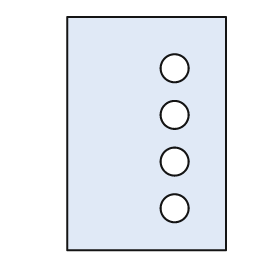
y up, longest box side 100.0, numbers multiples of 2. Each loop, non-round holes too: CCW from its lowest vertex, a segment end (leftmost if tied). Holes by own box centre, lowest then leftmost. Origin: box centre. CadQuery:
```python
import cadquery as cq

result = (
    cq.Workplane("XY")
    .moveTo(-34.0, -50.0)
    .lineTo(34.0, -50.0)
    .lineTo(34.0, 50.0)
    .lineTo(-34.0, 50.0)
    .close()
    .moveTo(12.0, -32.0)
    .circle(6.0)
    .moveTo(12.0, -12.0)
    .circle(6.0)
    .moveTo(12.0, 8.0)
    .circle(6.0)
    .moveTo(12.0, 28.0)
    .circle(6.0)
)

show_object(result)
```